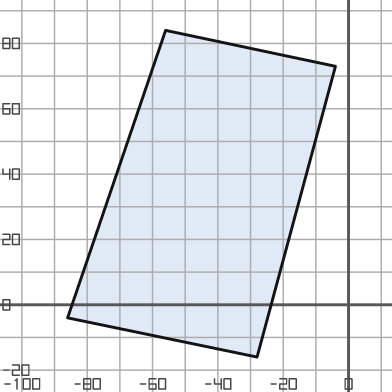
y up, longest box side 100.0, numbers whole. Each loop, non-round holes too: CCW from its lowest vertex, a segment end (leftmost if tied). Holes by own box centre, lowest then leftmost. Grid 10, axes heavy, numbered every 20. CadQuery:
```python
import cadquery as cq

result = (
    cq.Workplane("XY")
    .moveTo(-28.0, -16.0)
    .lineTo(-4.0, 73.0)
    .lineTo(-56.0, 84.0)
    .lineTo(-86.0, -4.0)
    .close()
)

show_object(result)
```